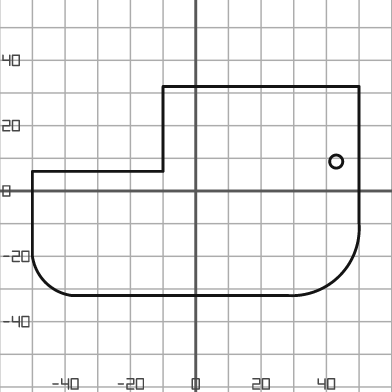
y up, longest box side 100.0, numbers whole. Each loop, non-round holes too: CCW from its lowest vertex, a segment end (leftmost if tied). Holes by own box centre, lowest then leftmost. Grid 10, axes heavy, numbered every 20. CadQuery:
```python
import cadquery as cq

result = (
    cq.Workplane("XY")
    .moveTo(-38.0, -32.0)
    .lineTo(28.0, -32.0)
    .threePointArc((44.0, -26.0), (50.0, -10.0))
    .lineTo(50.0, 32.0)
    .lineTo(-10.0, 32.0)
    .lineTo(-10.0, 6.0)
    .lineTo(-50.0, 6.0)
    .lineTo(-50.0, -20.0)
    .threePointArc((-46.0, -28.0), (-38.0, -32.0))
    .close()
    .moveTo(43.0, 9.0)
    .circle(2.0)
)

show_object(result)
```